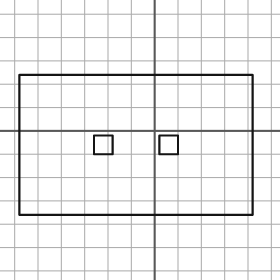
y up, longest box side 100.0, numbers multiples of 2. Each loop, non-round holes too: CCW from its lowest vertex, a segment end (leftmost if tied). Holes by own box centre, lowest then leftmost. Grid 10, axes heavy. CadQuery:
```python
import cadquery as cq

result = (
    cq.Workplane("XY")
    .moveTo(-58.0, -36.0)
    .lineTo(42.0, -36.0)
    .lineTo(42.0, 24.0)
    .lineTo(-58.0, 24.0)
    .close()
    .moveTo(-26.0, -10.0)
    .lineTo(-18.0, -10.0)
    .lineTo(-18.0, -2.0)
    .lineTo(-26.0, -2.0)
    .close()
    .moveTo(2.0, -10.0)
    .lineTo(10.0, -10.0)
    .lineTo(10.0, -2.0)
    .lineTo(2.0, -2.0)
    .close()
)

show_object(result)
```